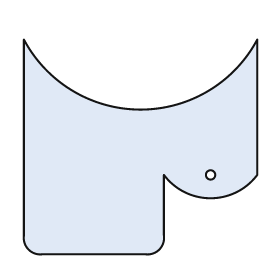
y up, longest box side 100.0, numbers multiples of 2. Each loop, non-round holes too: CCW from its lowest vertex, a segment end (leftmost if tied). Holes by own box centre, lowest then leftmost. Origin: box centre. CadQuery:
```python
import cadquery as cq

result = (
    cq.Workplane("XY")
    .moveTo(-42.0, -46.0)
    .lineTo(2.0, -46.0)
    .threePointArc((8.0, -44.0), (10.0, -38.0))
    .lineTo(10.0, -12.0)
    .threePointArc((30.0, -22.0), (50.0, -12.0))
    .lineTo(50.0, 46.0)
    .threePointArc((0.0, 16.0), (-50.0, 46.0))
    .lineTo(-50.0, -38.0)
    .threePointArc((-48.0, -44.0), (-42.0, -46.0))
    .close()
    .moveTo(30.0, -12.0)
    .circle(2.0)
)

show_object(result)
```